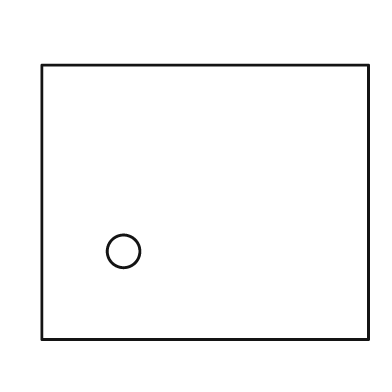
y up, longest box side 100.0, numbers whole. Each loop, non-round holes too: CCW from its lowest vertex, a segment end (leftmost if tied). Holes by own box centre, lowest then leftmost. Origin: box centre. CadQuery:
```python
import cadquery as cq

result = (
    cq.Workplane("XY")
    .moveTo(-50.0, -42.0)
    .lineTo(50.0, -42.0)
    .lineTo(50.0, 42.0)
    .lineTo(-50.0, 42.0)
    .close()
    .moveTo(-25.0, -15.0)
    .circle(5.0)
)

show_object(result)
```